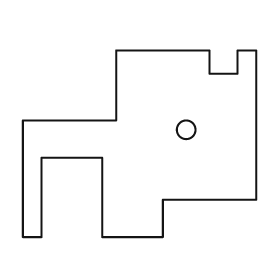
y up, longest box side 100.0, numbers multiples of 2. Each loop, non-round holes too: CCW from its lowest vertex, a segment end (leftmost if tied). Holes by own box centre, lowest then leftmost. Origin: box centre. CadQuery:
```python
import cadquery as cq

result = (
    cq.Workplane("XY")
    .moveTo(-50.0, -40.0)
    .lineTo(-42.0, -40.0)
    .lineTo(-42.0, -6.0)
    .lineTo(-16.0, -6.0)
    .lineTo(-16.0, -40.0)
    .lineTo(10.0, -40.0)
    .lineTo(10.0, -24.0)
    .lineTo(50.0, -24.0)
    .lineTo(50.0, 40.0)
    .lineTo(42.0, 40.0)
    .lineTo(42.0, 30.0)
    .lineTo(30.0, 30.0)
    .lineTo(30.0, 40.0)
    .lineTo(-10.0, 40.0)
    .lineTo(-10.0, 10.0)
    .lineTo(-50.0, 10.0)
    .close()
    .moveTo(20.0, 6.0)
    .circle(4.0)
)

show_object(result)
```